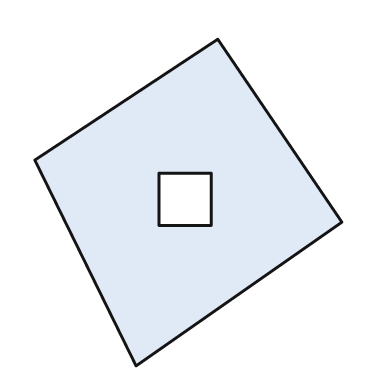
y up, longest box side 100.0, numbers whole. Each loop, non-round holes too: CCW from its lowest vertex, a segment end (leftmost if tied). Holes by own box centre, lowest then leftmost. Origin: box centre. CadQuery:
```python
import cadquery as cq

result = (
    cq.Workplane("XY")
    .moveTo(-16.0, -50.0)
    .lineTo(47.0, -6.0)
    .lineTo(9.0, 50.0)
    .lineTo(-47.0, 13.0)
    .close()
    .moveTo(-9.0, -7.0)
    .lineTo(7.0, -7.0)
    .lineTo(7.0, 9.0)
    .lineTo(-9.0, 9.0)
    .close()
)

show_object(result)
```